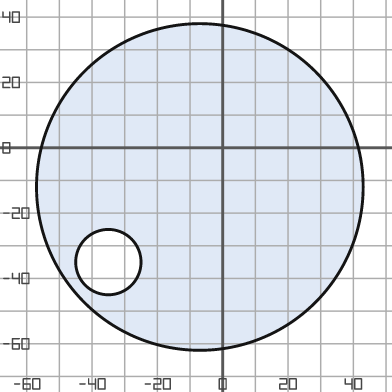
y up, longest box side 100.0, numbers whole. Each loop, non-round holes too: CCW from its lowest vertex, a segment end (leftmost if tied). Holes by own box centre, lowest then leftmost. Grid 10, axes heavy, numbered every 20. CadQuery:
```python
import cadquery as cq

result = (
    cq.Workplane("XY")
    .moveTo(-7.0, -12.0)
    .circle(50.0)
    .moveTo(-35.0, -35.0)
    .circle(10.0)
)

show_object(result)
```